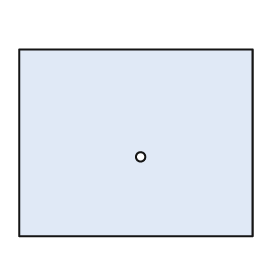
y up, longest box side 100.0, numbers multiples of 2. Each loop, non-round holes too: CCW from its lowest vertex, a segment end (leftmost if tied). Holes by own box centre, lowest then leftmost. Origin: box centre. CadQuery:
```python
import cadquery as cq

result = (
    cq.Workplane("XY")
    .moveTo(-50.0, -40.0)
    .lineTo(50.0, -40.0)
    .lineTo(50.0, 40.0)
    .lineTo(-50.0, 40.0)
    .close()
    .moveTo(2.0, -6.0)
    .circle(2.0)
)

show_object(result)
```